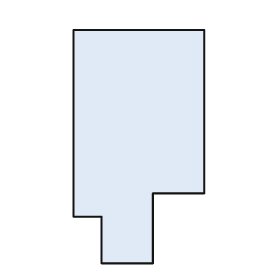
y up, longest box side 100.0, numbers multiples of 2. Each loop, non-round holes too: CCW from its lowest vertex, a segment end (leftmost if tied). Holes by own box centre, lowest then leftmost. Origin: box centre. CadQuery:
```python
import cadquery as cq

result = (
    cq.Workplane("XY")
    .moveTo(-16.0, -50.0)
    .lineTo(6.0, -50.0)
    .lineTo(6.0, -20.0)
    .lineTo(28.0, -20.0)
    .lineTo(28.0, 50.0)
    .lineTo(-28.0, 50.0)
    .lineTo(-28.0, -30.0)
    .lineTo(-16.0, -30.0)
    .close()
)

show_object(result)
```